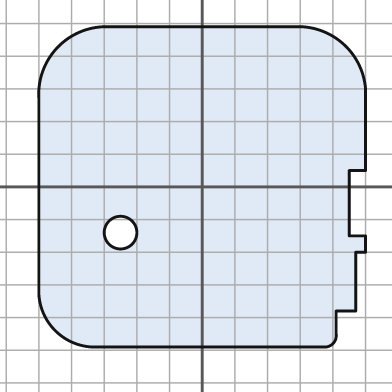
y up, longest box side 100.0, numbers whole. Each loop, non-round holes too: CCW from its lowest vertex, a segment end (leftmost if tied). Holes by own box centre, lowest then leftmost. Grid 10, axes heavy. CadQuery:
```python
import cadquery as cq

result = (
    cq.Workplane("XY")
    .moveTo(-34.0, -49.0)
    .lineTo(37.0, -49.0)
    .threePointArc((40.0, -48.0), (41.0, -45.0))
    .lineTo(41.0, -38.0)
    .lineTo(47.0, -38.0)
    .lineTo(47.0, -20.0)
    .lineTo(50.0, -20.0)
    .lineTo(50.0, -15.0)
    .lineTo(45.0, -15.0)
    .lineTo(45.0, 5.0)
    .lineTo(50.0, 5.0)
    .lineTo(50.0, 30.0)
    .threePointArc((44.0, 43.0), (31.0, 49.0))
    .lineTo(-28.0, 49.0)
    .threePointArc((-44.0, 43.0), (-50.0, 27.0))
    .lineTo(-50.0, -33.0)
    .threePointArc((-45.0, -44.0), (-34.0, -49.0))
    .close()
    .moveTo(-25.0, -14.0)
    .circle(5.0)
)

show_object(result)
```